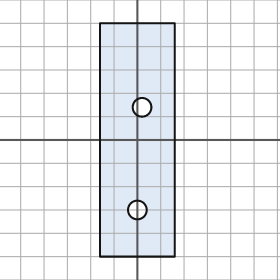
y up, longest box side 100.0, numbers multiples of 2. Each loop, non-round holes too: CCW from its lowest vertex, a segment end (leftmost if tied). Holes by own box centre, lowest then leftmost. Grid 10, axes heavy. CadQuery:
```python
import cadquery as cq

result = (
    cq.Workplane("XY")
    .moveTo(-16.0, -50.0)
    .lineTo(16.0, -50.0)
    .lineTo(16.0, 50.0)
    .lineTo(-16.0, 50.0)
    .close()
    .moveTo(0.0, -30.0)
    .circle(4.0)
    .moveTo(2.0, 14.0)
    .circle(4.0)
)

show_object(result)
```